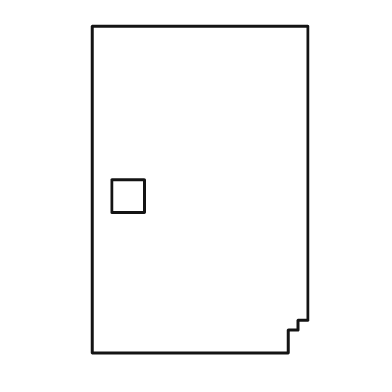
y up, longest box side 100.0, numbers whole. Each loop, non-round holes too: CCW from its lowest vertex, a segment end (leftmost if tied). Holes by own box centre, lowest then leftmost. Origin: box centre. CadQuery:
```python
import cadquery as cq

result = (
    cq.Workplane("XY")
    .moveTo(-33.0, -50.0)
    .lineTo(27.0, -50.0)
    .lineTo(27.0, -43.0)
    .lineTo(30.0, -43.0)
    .lineTo(30.0, -40.0)
    .lineTo(33.0, -40.0)
    .lineTo(33.0, 50.0)
    .lineTo(-33.0, 50.0)
    .close()
    .moveTo(-27.0, -7.0)
    .lineTo(-17.0, -7.0)
    .lineTo(-17.0, 3.0)
    .lineTo(-27.0, 3.0)
    .close()
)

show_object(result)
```